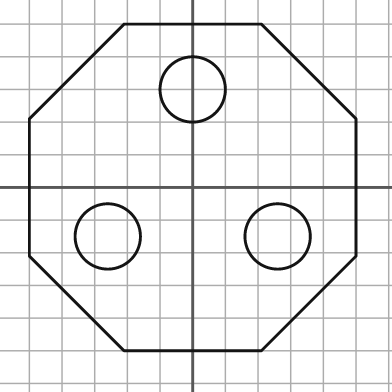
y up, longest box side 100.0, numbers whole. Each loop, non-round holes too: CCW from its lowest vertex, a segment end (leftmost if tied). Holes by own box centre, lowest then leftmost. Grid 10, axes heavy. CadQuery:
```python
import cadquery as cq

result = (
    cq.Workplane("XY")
    .moveTo(-21.0, -50.0)
    .lineTo(21.0, -50.0)
    .lineTo(50.0, -21.0)
    .lineTo(50.0, 21.0)
    .lineTo(21.0, 50.0)
    .lineTo(-21.0, 50.0)
    .lineTo(-50.0, 21.0)
    .lineTo(-50.0, -21.0)
    .close()
    .moveTo(-26.0, -15.0)
    .circle(10.0)
    .moveTo(26.0, -15.0)
    .circle(10.0)
    .moveTo(0.0, 30.0)
    .circle(10.0)
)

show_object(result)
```